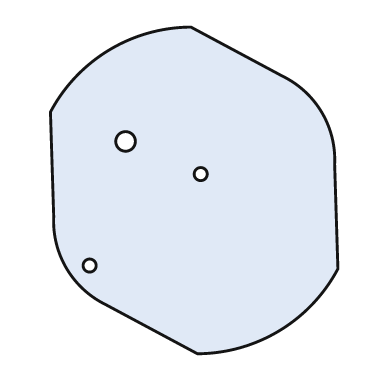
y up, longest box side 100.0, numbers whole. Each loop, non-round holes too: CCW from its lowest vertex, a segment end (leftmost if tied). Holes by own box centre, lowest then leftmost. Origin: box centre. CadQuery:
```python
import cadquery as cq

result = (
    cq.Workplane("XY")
    .moveTo(1.0, -50.0)
    .threePointArc((26.0, -43.0), (44.0, -24.0))
    .lineTo(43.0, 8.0)
    .threePointArc((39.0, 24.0), (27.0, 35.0))
    .lineTo(-1.0, 50.0)
    .threePointArc((-26.0, 43.0), (-44.0, 24.0))
    .lineTo(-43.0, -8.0)
    .threePointArc((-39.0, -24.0), (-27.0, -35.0))
    .close()
    .moveTo(-32.0, -23.0)
    .circle(2.0)
    .moveTo(2.0, 5.0)
    .circle(2.0)
    .moveTo(-21.0, 15.0)
    .circle(3.0)
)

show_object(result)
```